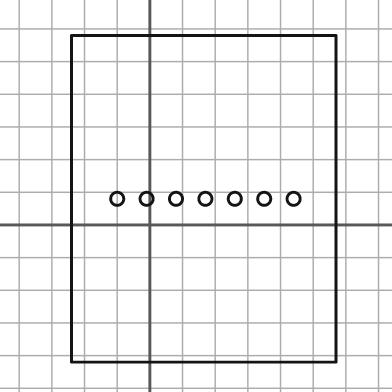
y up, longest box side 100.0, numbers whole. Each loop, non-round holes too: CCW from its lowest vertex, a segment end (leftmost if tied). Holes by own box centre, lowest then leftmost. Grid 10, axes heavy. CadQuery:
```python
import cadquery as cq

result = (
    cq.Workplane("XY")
    .moveTo(-24.0, -42.0)
    .lineTo(57.0, -42.0)
    .lineTo(57.0, 58.0)
    .lineTo(-24.0, 58.0)
    .close()
    .moveTo(-10.0, 8.0)
    .circle(2.0)
    .moveTo(-1.0, 8.0)
    .circle(2.0)
    .moveTo(8.0, 8.0)
    .circle(2.0)
    .moveTo(17.0, 8.0)
    .circle(2.0)
    .moveTo(26.0, 8.0)
    .circle(2.0)
    .moveTo(35.0, 8.0)
    .circle(2.0)
    .moveTo(44.0, 8.0)
    .circle(2.0)
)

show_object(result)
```